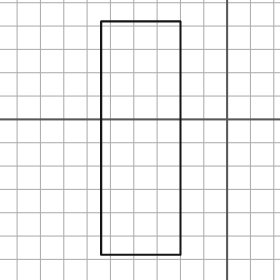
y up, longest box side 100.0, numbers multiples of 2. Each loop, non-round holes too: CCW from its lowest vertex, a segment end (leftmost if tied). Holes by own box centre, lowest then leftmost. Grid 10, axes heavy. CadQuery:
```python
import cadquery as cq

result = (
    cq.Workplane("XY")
    .moveTo(-54.0, -58.0)
    .lineTo(-20.0, -58.0)
    .lineTo(-20.0, 42.0)
    .lineTo(-54.0, 42.0)
    .close()
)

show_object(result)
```